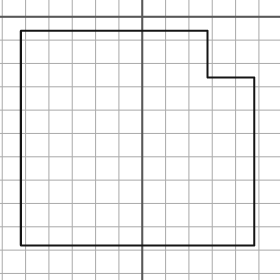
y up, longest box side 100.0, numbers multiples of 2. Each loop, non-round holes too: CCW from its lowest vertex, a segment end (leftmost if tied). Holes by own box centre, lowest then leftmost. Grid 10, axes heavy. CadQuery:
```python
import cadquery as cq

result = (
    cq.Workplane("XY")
    .moveTo(-52.0, -98.0)
    .lineTo(48.0, -98.0)
    .lineTo(48.0, -26.0)
    .lineTo(28.0, -26.0)
    .lineTo(28.0, -6.0)
    .lineTo(-52.0, -6.0)
    .close()
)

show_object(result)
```